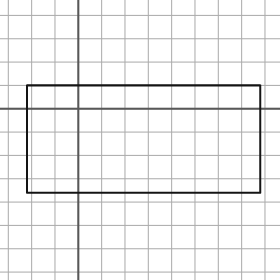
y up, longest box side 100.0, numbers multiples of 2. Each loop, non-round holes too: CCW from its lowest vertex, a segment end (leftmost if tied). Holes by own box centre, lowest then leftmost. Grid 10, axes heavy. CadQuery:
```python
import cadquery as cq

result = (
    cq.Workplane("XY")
    .moveTo(-22.0, -36.0)
    .lineTo(78.0, -36.0)
    .lineTo(78.0, 10.0)
    .lineTo(-22.0, 10.0)
    .close()
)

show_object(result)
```